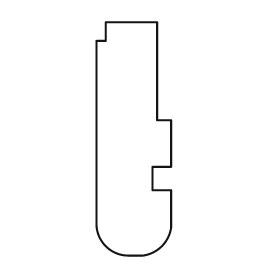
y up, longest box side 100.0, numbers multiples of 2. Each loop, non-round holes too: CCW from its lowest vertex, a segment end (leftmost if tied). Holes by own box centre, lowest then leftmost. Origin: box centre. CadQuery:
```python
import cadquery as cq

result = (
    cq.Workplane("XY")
    .moveTo(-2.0, -50.0)
    .lineTo(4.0, -50.0)
    .threePointArc((12.0, -46.0), (16.0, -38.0))
    .lineTo(16.0, -22.0)
    .lineTo(8.0, -22.0)
    .lineTo(8.0, -12.0)
    .lineTo(16.0, -12.0)
    .lineTo(16.0, 8.0)
    .lineTo(10.0, 8.0)
    .lineTo(10.0, 50.0)
    .lineTo(-12.0, 50.0)
    .lineTo(-12.0, 42.0)
    .lineTo(-16.0, 42.0)
    .lineTo(-16.0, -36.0)
    .threePointArc((-12.0, -46.0), (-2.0, -50.0))
    .close()
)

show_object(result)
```